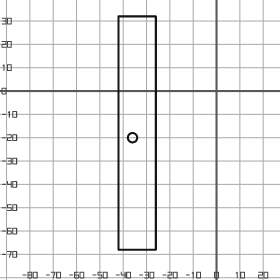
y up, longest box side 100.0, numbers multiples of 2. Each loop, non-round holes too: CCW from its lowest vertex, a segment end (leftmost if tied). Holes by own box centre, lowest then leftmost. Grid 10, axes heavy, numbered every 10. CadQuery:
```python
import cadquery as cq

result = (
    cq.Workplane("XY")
    .moveTo(-42.0, -68.0)
    .lineTo(-26.0, -68.0)
    .lineTo(-26.0, 32.0)
    .lineTo(-42.0, 32.0)
    .close()
    .moveTo(-36.0, -20.0)
    .circle(2.0)
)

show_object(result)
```